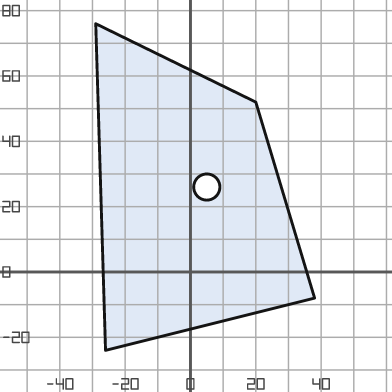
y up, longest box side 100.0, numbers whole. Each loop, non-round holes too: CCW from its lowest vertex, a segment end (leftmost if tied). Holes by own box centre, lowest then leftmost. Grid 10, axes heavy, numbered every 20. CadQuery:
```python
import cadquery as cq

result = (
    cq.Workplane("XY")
    .moveTo(-26.0, -24.0)
    .lineTo(38.0, -8.0)
    .lineTo(20.0, 52.0)
    .lineTo(-29.0, 76.0)
    .close()
    .moveTo(5.0, 26.0)
    .circle(4.0)
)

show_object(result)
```